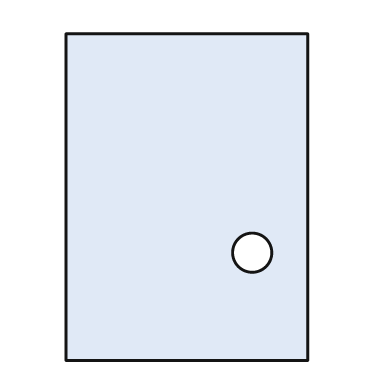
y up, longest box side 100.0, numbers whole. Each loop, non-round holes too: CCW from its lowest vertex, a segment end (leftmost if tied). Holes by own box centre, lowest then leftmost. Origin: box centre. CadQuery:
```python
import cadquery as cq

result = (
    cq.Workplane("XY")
    .moveTo(-37.0, -50.0)
    .lineTo(37.0, -50.0)
    .lineTo(37.0, 50.0)
    .lineTo(-37.0, 50.0)
    .close()
    .moveTo(20.0, -17.0)
    .circle(6.0)
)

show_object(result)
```